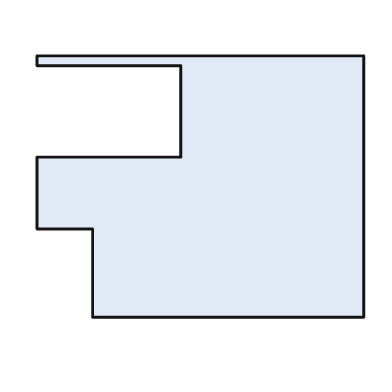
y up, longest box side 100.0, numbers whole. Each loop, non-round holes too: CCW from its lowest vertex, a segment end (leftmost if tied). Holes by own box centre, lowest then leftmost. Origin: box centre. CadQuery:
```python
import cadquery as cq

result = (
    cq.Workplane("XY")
    .moveTo(-33.0, -40.0)
    .lineTo(50.0, -40.0)
    .lineTo(50.0, 40.0)
    .lineTo(-50.0, 40.0)
    .lineTo(-50.0, 37.0)
    .lineTo(-6.0, 37.0)
    .lineTo(-6.0, 9.0)
    .lineTo(-50.0, 9.0)
    .lineTo(-50.0, -13.0)
    .lineTo(-33.0, -13.0)
    .close()
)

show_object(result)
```